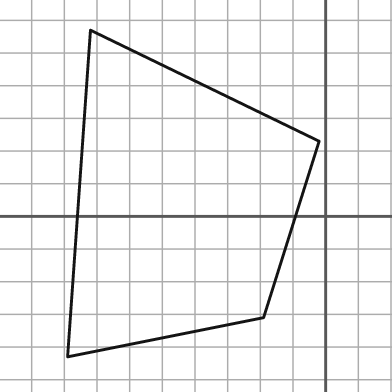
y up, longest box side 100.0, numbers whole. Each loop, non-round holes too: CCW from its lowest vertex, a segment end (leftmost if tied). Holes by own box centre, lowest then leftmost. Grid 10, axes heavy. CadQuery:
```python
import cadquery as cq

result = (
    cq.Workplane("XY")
    .moveTo(-79.0, -43.0)
    .lineTo(-19.0, -31.0)
    .lineTo(-2.0, 23.0)
    .lineTo(-72.0, 57.0)
    .close()
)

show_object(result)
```